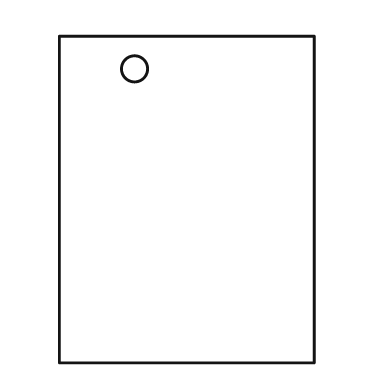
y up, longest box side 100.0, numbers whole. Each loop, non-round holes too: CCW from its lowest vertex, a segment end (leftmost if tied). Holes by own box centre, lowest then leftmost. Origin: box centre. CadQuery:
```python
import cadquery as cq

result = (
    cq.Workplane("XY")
    .moveTo(-39.0, -50.0)
    .lineTo(39.0, -50.0)
    .lineTo(39.0, 50.0)
    .lineTo(-39.0, 50.0)
    .close()
    .moveTo(-16.0, 40.0)
    .circle(4.0)
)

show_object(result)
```